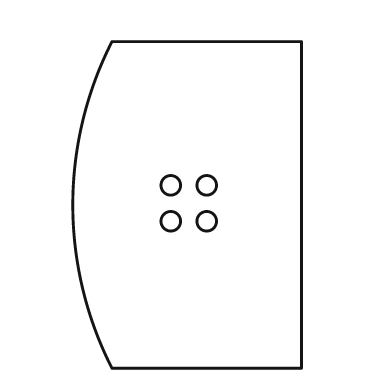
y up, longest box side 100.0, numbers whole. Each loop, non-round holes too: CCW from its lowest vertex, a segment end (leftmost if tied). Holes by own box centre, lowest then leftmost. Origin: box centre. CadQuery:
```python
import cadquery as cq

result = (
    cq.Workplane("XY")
    .moveTo(-23.0, -50.0)
    .lineTo(35.0, -50.0)
    .lineTo(35.0, 50.0)
    .lineTo(-23.0, 50.0)
    .threePointArc((-35.0, 0.0), (-23.0, -50.0))
    .close()
    .moveTo(-5.0, -5.0)
    .circle(3.0)
    .moveTo(6.0, -5.0)
    .circle(3.0)
    .moveTo(-5.0, 6.0)
    .circle(3.0)
    .moveTo(6.0, 6.0)
    .circle(3.0)
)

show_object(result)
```